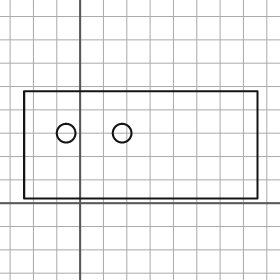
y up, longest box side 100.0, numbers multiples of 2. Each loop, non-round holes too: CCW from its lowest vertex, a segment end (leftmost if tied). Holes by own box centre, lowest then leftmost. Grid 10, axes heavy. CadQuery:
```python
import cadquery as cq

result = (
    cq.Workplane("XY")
    .moveTo(-24.0, 2.0)
    .lineTo(76.0, 2.0)
    .lineTo(76.0, 48.0)
    .lineTo(-24.0, 48.0)
    .close()
    .moveTo(-6.0, 30.0)
    .circle(4.0)
    .moveTo(18.0, 30.0)
    .circle(4.0)
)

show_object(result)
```